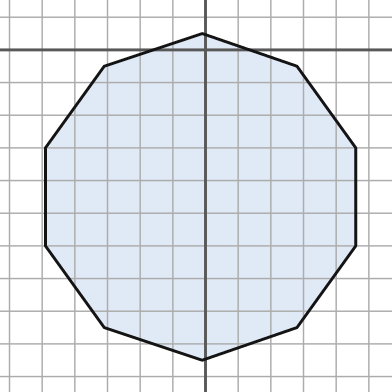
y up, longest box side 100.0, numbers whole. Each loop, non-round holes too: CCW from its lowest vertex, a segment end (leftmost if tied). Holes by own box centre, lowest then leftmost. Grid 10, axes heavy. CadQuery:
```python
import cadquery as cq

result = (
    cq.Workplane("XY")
    .moveTo(-1.0, -95.0)
    .lineTo(28.0, -85.0)
    .lineTo(46.0, -60.0)
    .lineTo(46.0, -30.0)
    .lineTo(28.0, -5.0)
    .lineTo(-1.0, 5.0)
    .lineTo(-31.0, -5.0)
    .lineTo(-49.0, -30.0)
    .lineTo(-49.0, -60.0)
    .lineTo(-31.0, -85.0)
    .close()
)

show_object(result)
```